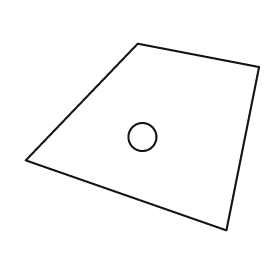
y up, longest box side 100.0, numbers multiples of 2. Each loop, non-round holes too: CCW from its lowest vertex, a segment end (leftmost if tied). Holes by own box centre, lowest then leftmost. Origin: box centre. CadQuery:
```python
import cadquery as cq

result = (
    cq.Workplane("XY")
    .moveTo(36.0, -40.0)
    .lineTo(50.0, 30.0)
    .lineTo(-2.0, 40.0)
    .lineTo(-50.0, -10.0)
    .close()
    .moveTo(0.0, 0.0)
    .circle(6.0)
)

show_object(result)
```